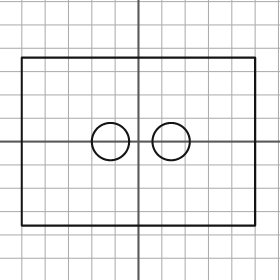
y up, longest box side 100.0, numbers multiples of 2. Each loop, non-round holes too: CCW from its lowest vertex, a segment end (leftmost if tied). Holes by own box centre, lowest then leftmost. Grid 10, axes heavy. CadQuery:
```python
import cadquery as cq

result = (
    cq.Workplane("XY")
    .moveTo(-50.0, -36.0)
    .lineTo(50.0, -36.0)
    .lineTo(50.0, 36.0)
    .lineTo(-50.0, 36.0)
    .close()
    .moveTo(-12.0, 0.0)
    .circle(8.0)
    .moveTo(14.0, 0.0)
    .circle(8.0)
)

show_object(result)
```